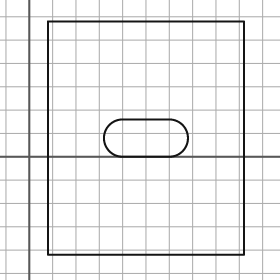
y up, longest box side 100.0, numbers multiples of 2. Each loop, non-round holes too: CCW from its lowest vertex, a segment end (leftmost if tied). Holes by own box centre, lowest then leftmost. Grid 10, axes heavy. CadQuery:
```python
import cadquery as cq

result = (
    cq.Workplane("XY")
    .moveTo(8.0, -42.0)
    .lineTo(92.0, -42.0)
    .lineTo(92.0, 58.0)
    .lineTo(8.0, 58.0)
    .close()
    .moveTo(40.0, 0.0)
    .lineTo(60.0, 0.0)
    .threePointArc((68.0, 8.0), (60.0, 16.0))
    .lineTo(40.0, 16.0)
    .threePointArc((32.0, 8.0), (40.0, 0.0))
    .close()
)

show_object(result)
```